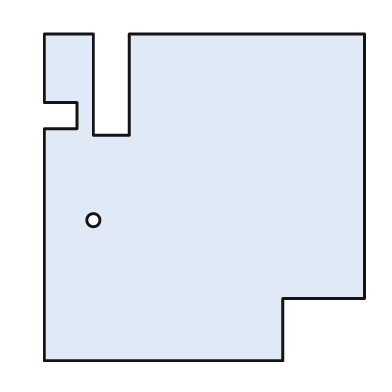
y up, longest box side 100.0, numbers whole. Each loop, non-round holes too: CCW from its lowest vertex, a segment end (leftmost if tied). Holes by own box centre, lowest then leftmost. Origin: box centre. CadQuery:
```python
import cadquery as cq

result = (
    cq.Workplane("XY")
    .moveTo(-49.0, -50.0)
    .lineTo(24.0, -50.0)
    .lineTo(24.0, -31.0)
    .lineTo(49.0, -31.0)
    .lineTo(49.0, 50.0)
    .lineTo(-23.0, 50.0)
    .lineTo(-23.0, 19.0)
    .lineTo(-34.0, 19.0)
    .lineTo(-34.0, 50.0)
    .lineTo(-49.0, 50.0)
    .lineTo(-49.0, 29.0)
    .lineTo(-39.0, 29.0)
    .lineTo(-39.0, 21.0)
    .lineTo(-49.0, 21.0)
    .close()
    .moveTo(-34.0, -7.0)
    .circle(2.0)
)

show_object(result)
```